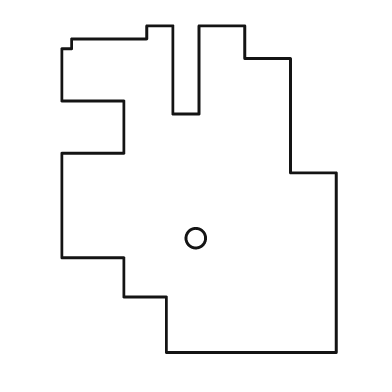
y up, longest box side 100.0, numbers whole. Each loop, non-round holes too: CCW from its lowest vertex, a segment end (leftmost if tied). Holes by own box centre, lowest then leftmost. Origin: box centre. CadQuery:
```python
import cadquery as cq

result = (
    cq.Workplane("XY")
    .moveTo(-10.0, -50.0)
    .lineTo(42.0, -50.0)
    .lineTo(42.0, 5.0)
    .lineTo(28.0, 5.0)
    .lineTo(28.0, 40.0)
    .lineTo(14.0, 40.0)
    .lineTo(14.0, 50.0)
    .lineTo(0.0, 50.0)
    .lineTo(0.0, 23.0)
    .lineTo(-8.0, 23.0)
    .lineTo(-8.0, 50.0)
    .lineTo(-16.0, 50.0)
    .lineTo(-16.0, 46.0)
    .lineTo(-39.0, 46.0)
    .lineTo(-39.0, 43.0)
    .lineTo(-42.0, 43.0)
    .lineTo(-42.0, 27.0)
    .lineTo(-23.0, 27.0)
    .lineTo(-23.0, 11.0)
    .lineTo(-42.0, 11.0)
    .lineTo(-42.0, -21.0)
    .lineTo(-23.0, -21.0)
    .lineTo(-23.0, -33.0)
    .lineTo(-10.0, -33.0)
    .close()
    .moveTo(-1.0, -15.0)
    .circle(3.0)
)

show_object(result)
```